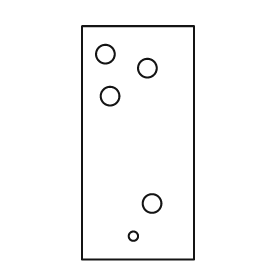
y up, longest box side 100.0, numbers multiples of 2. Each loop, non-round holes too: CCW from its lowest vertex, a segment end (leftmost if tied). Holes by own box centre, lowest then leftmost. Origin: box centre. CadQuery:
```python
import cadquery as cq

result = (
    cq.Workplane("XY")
    .moveTo(-24.0, -50.0)
    .lineTo(24.0, -50.0)
    .lineTo(24.0, 50.0)
    .lineTo(-24.0, 50.0)
    .close()
    .moveTo(-2.0, -40.0)
    .circle(2.0)
    .moveTo(6.0, -26.0)
    .circle(4.0)
    .moveTo(-12.0, 20.0)
    .circle(4.0)
    .moveTo(4.0, 32.0)
    .circle(4.0)
    .moveTo(-14.0, 38.0)
    .circle(4.0)
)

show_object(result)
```